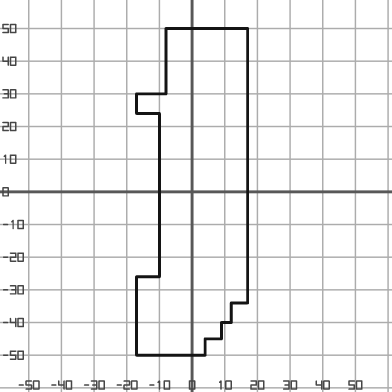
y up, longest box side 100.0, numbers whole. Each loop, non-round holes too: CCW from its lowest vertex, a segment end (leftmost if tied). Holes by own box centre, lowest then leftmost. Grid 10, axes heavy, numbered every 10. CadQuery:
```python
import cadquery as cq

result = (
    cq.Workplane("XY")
    .moveTo(-17.0, -50.0)
    .lineTo(4.0, -50.0)
    .lineTo(4.0, -45.0)
    .lineTo(9.0, -45.0)
    .lineTo(9.0, -40.0)
    .lineTo(12.0, -40.0)
    .lineTo(12.0, -34.0)
    .lineTo(17.0, -34.0)
    .lineTo(17.0, 50.0)
    .lineTo(-8.0, 50.0)
    .lineTo(-8.0, 30.0)
    .lineTo(-17.0, 30.0)
    .lineTo(-17.0, 24.0)
    .lineTo(-10.0, 24.0)
    .lineTo(-10.0, -26.0)
    .lineTo(-17.0, -26.0)
    .close()
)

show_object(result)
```